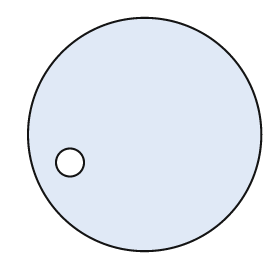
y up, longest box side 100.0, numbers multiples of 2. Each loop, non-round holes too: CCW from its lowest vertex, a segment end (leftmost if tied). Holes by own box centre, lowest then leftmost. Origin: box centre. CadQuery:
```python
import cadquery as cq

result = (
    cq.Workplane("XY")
    .moveTo(0.0, 0.0)
    .circle(50.0)
    .moveTo(-32.0, -12.0)
    .circle(6.0)
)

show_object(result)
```